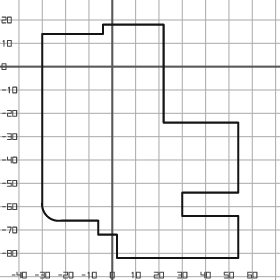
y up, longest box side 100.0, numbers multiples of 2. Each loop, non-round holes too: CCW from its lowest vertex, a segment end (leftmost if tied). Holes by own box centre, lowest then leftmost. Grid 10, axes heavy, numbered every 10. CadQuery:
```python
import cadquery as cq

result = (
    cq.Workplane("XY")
    .moveTo(2.0, -82.0)
    .lineTo(54.0, -82.0)
    .lineTo(54.0, -64.0)
    .lineTo(30.0, -64.0)
    .lineTo(30.0, -54.0)
    .lineTo(54.0, -54.0)
    .lineTo(54.0, -24.0)
    .lineTo(22.0, -24.0)
    .lineTo(22.0, 18.0)
    .lineTo(-4.0, 18.0)
    .lineTo(-4.0, 14.0)
    .lineTo(-30.0, 14.0)
    .lineTo(-30.0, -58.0)
    .threePointArc((-28.0, -64.0), (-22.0, -66.0))
    .lineTo(-6.0, -66.0)
    .lineTo(-6.0, -72.0)
    .lineTo(2.0, -72.0)
    .close()
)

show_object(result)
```